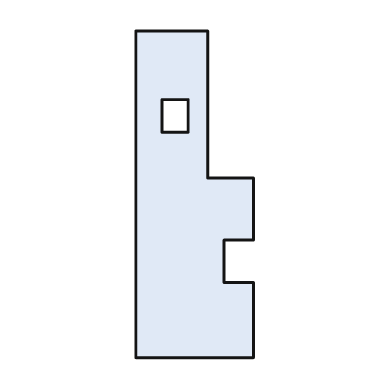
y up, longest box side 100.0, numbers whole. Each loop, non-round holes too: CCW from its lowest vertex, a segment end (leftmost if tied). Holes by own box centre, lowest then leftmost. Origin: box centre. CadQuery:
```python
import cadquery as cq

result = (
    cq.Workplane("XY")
    .moveTo(-18.0, -50.0)
    .lineTo(18.0, -50.0)
    .lineTo(18.0, -27.0)
    .lineTo(9.0, -27.0)
    .lineTo(9.0, -14.0)
    .lineTo(18.0, -14.0)
    .lineTo(18.0, 5.0)
    .lineTo(4.0, 5.0)
    .lineTo(4.0, 50.0)
    .lineTo(-18.0, 50.0)
    .close()
    .moveTo(-10.0, 19.0)
    .lineTo(-2.0, 19.0)
    .lineTo(-2.0, 29.0)
    .lineTo(-10.0, 29.0)
    .close()
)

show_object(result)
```